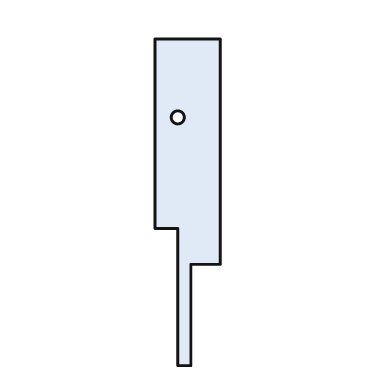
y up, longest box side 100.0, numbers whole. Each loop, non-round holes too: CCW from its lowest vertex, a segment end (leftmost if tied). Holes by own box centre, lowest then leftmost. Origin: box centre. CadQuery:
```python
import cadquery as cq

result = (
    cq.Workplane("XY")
    .moveTo(-3.0, -50.0)
    .lineTo(1.0, -50.0)
    .lineTo(1.0, -19.0)
    .lineTo(10.0, -19.0)
    .lineTo(10.0, 50.0)
    .lineTo(-10.0, 50.0)
    .lineTo(-10.0, -8.0)
    .lineTo(-3.0, -8.0)
    .close()
    .moveTo(-3.0, 26.0)
    .circle(2.0)
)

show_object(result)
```